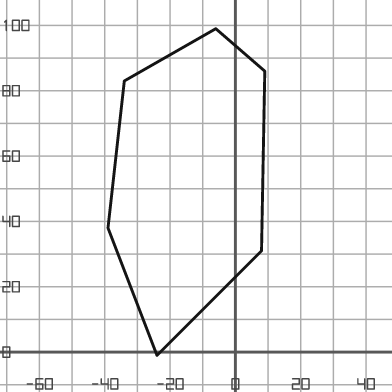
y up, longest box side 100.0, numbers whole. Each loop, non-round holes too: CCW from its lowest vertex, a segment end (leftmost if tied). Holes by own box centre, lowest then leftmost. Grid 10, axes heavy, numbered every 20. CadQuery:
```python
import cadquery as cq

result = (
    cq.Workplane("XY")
    .moveTo(-24.0, -1.0)
    .lineTo(8.0, 31.0)
    .lineTo(9.0, 86.0)
    .lineTo(-6.0, 99.0)
    .lineTo(-34.0, 83.0)
    .lineTo(-39.0, 38.0)
    .close()
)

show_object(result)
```